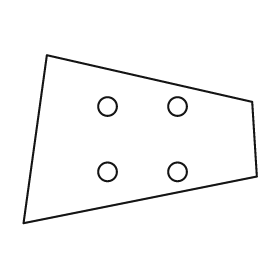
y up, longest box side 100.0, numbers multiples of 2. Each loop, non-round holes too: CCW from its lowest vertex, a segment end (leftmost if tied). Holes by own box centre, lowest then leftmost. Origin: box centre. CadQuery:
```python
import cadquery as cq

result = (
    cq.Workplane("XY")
    .moveTo(-50.0, -36.0)
    .lineTo(50.0, -16.0)
    .lineTo(48.0, 16.0)
    .lineTo(-40.0, 36.0)
    .close()
    .moveTo(-14.0, -14.0)
    .circle(4.0)
    .moveTo(16.0, -14.0)
    .circle(4.0)
    .moveTo(-14.0, 14.0)
    .circle(4.0)
    .moveTo(16.0, 14.0)
    .circle(4.0)
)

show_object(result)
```